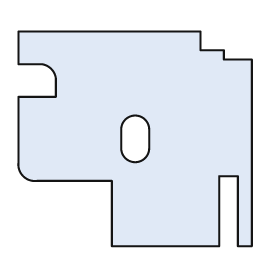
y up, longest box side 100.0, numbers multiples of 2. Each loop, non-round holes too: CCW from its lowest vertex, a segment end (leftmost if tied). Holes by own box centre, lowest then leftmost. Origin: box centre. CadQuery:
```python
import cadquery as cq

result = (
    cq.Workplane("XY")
    .moveTo(-10.0, -46.0)
    .lineTo(36.0, -46.0)
    .lineTo(36.0, -16.0)
    .lineTo(44.0, -16.0)
    .lineTo(44.0, -46.0)
    .lineTo(50.0, -46.0)
    .lineTo(50.0, 34.0)
    .lineTo(38.0, 34.0)
    .lineTo(38.0, 38.0)
    .lineTo(28.0, 38.0)
    .lineTo(28.0, 46.0)
    .lineTo(-50.0, 46.0)
    .lineTo(-50.0, 32.0)
    .lineTo(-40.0, 32.0)
    .threePointArc((-36.0, 30.0), (-34.0, 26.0))
    .lineTo(-34.0, 18.0)
    .lineTo(-50.0, 18.0)
    .lineTo(-50.0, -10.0)
    .threePointArc((-48.0, -16.0), (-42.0, -18.0))
    .lineTo(-10.0, -18.0)
    .close()
    .moveTo(-6.0, -4.0)
    .threePointArc((0.0, -10.0), (6.0, -4.0))
    .lineTo(6.0, 4.0)
    .threePointArc((0.0, 10.0), (-6.0, 4.0))
    .close()
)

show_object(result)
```